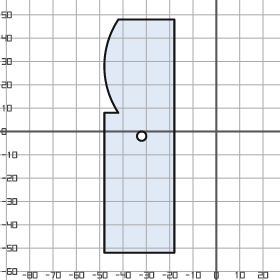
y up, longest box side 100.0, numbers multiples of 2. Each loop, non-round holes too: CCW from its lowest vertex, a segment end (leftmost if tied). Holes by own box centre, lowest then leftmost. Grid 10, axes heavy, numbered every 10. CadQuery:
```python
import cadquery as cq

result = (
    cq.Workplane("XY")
    .moveTo(-48.0, -52.0)
    .lineTo(-18.0, -52.0)
    .lineTo(-18.0, 48.0)
    .lineTo(-42.0, 48.0)
    .threePointArc((-48.0, 28.0), (-42.0, 8.0))
    .lineTo(-48.0, 8.0)
    .close()
    .moveTo(-32.0, -2.0)
    .circle(2.0)
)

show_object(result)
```